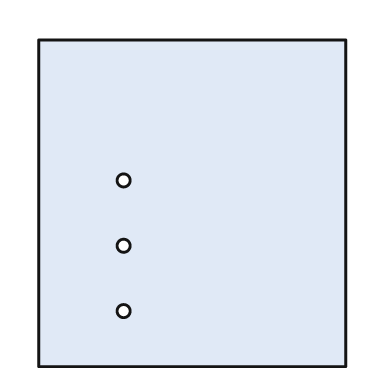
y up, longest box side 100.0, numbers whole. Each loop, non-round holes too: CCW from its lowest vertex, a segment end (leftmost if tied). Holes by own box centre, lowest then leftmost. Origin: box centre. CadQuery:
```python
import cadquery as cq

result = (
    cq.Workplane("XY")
    .moveTo(-47.0, -50.0)
    .lineTo(47.0, -50.0)
    .lineTo(47.0, 50.0)
    .lineTo(-47.0, 50.0)
    .close()
    .moveTo(-21.0, -33.0)
    .circle(2.0)
    .moveTo(-21.0, -13.0)
    .circle(2.0)
    .moveTo(-21.0, 7.0)
    .circle(2.0)
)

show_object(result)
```